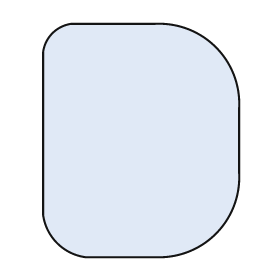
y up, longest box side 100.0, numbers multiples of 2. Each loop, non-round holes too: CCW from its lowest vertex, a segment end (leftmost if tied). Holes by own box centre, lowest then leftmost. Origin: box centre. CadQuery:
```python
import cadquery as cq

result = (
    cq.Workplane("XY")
    .moveTo(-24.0, -50.0)
    .lineTo(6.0, -50.0)
    .threePointArc((32.0, -40.0), (42.0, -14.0))
    .lineTo(42.0, 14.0)
    .threePointArc((32.0, 40.0), (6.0, 50.0))
    .lineTo(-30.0, 50.0)
    .threePointArc((-38.0, 46.0), (-42.0, 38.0))
    .lineTo(-42.0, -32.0)
    .threePointArc((-36.0, -44.0), (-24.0, -50.0))
    .close()
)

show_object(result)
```